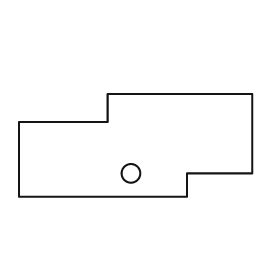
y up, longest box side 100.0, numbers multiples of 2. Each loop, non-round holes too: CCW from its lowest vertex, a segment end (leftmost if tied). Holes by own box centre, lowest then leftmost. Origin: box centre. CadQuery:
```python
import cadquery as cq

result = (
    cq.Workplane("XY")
    .moveTo(-50.0, -22.0)
    .lineTo(22.0, -22.0)
    .lineTo(22.0, -12.0)
    .lineTo(50.0, -12.0)
    .lineTo(50.0, 22.0)
    .lineTo(-12.0, 22.0)
    .lineTo(-12.0, 10.0)
    .lineTo(-50.0, 10.0)
    .close()
    .moveTo(-2.0, -12.0)
    .circle(4.0)
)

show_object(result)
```